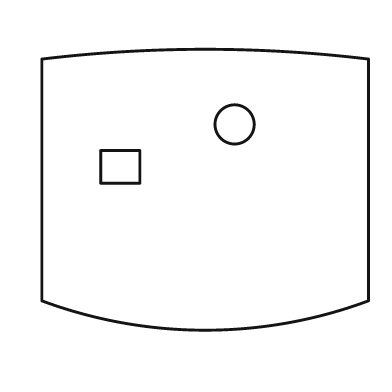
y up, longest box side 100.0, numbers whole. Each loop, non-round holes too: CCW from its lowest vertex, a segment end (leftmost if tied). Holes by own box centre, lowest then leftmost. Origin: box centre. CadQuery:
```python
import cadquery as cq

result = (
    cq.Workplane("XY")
    .moveTo(-50.0, -34.0)
    .threePointArc((0.0, -43.0), (50.0, -34.0))
    .lineTo(50.0, 40.0)
    .threePointArc((0.0, 43.0), (-50.0, 40.0))
    .close()
    .moveTo(-32.0, 2.0)
    .lineTo(-20.0, 2.0)
    .lineTo(-20.0, 12.0)
    .lineTo(-32.0, 12.0)
    .close()
    .moveTo(9.0, 20.0)
    .circle(6.0)
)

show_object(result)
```